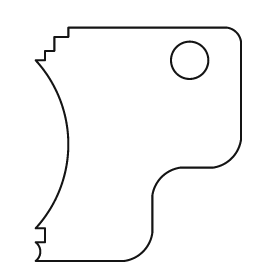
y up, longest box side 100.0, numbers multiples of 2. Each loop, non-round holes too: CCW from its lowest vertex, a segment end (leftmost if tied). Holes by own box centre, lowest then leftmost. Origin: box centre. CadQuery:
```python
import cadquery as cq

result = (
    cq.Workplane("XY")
    .moveTo(-44.0, -50.0)
    .lineTo(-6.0, -50.0)
    .threePointArc((2.0, -46.0), (6.0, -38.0))
    .lineTo(6.0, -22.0)
    .threePointArc((10.0, -14.0), (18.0, -10.0))
    .lineTo(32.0, -10.0)
    .threePointArc((40.0, -6.0), (44.0, 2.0))
    .lineTo(44.0, 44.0)
    .threePointArc((42.0, 48.0), (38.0, 50.0))
    .lineTo(-30.0, 50.0)
    .lineTo(-30.0, 46.0)
    .lineTo(-36.0, 46.0)
    .lineTo(-36.0, 40.0)
    .lineTo(-40.0, 40.0)
    .lineTo(-40.0, 36.0)
    .lineTo(-44.0, 36.0)
    .threePointArc((-30.0, 0.0), (-44.0, -36.0))
    .lineTo(-40.0, -36.0)
    .lineTo(-40.0, -42.0)
    .lineTo(-44.0, -42.0)
    .threePointArc((-42.0, -46.0), (-44.0, -50.0))
    .close()
    .moveTo(22.0, 36.0)
    .circle(8.0)
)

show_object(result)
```